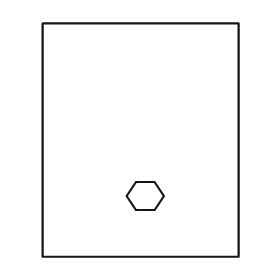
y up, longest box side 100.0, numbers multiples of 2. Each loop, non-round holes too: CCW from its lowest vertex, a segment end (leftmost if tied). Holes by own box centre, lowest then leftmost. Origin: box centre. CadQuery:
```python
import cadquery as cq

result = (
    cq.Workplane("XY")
    .moveTo(-42.0, -50.0)
    .lineTo(42.0, -50.0)
    .lineTo(42.0, 50.0)
    .lineTo(-42.0, 50.0)
    .close()
    .moveTo(-2.0, -30.0)
    .lineTo(6.0, -30.0)
    .lineTo(10.0, -24.0)
    .lineTo(6.0, -18.0)
    .lineTo(-2.0, -18.0)
    .lineTo(-6.0, -24.0)
    .close()
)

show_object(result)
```